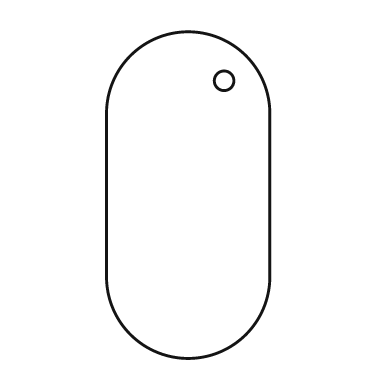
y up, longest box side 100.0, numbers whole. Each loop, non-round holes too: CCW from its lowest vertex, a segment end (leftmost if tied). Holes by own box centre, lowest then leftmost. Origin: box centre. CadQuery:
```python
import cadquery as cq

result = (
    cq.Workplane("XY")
    .moveTo(-25.0, -25.0)
    .threePointArc((0.0, -50.0), (25.0, -25.0))
    .lineTo(25.0, 25.0)
    .threePointArc((0.0, 50.0), (-25.0, 25.0))
    .close()
    .moveTo(11.0, 35.0)
    .circle(3.0)
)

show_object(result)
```